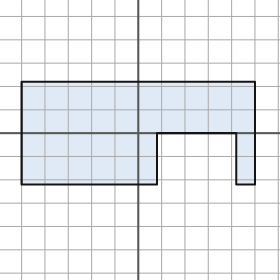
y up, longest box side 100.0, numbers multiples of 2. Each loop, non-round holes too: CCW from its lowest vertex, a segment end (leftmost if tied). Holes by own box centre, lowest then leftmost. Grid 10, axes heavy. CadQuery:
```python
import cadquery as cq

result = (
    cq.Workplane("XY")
    .moveTo(-50.0, -22.0)
    .lineTo(8.0, -22.0)
    .lineTo(8.0, 0.0)
    .lineTo(42.0, 0.0)
    .lineTo(42.0, -22.0)
    .lineTo(50.0, -22.0)
    .lineTo(50.0, 22.0)
    .lineTo(-50.0, 22.0)
    .close()
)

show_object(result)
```